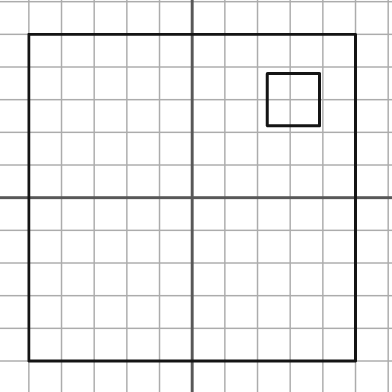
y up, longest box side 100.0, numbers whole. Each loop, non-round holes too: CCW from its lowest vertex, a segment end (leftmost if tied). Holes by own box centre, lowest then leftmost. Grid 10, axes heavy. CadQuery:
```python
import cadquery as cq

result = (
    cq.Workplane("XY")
    .moveTo(-50.0, -50.0)
    .lineTo(50.0, -50.0)
    .lineTo(50.0, 50.0)
    .lineTo(-50.0, 50.0)
    .close()
    .moveTo(23.0, 22.0)
    .lineTo(39.0, 22.0)
    .lineTo(39.0, 38.0)
    .lineTo(23.0, 38.0)
    .close()
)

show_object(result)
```